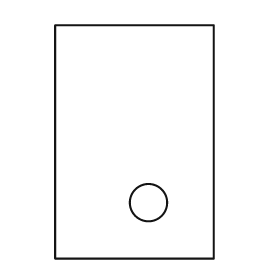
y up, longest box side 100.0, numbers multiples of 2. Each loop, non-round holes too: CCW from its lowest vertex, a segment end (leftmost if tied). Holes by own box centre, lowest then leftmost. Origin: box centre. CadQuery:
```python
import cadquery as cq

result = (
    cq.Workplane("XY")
    .moveTo(-34.0, -50.0)
    .lineTo(34.0, -50.0)
    .lineTo(34.0, 50.0)
    .lineTo(-34.0, 50.0)
    .close()
    .moveTo(6.0, -26.0)
    .circle(8.0)
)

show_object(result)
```